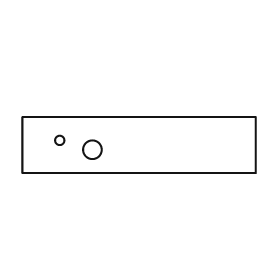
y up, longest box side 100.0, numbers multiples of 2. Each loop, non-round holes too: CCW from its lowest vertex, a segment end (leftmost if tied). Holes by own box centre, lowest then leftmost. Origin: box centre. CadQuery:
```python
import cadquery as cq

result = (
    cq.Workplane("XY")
    .moveTo(-50.0, -12.0)
    .lineTo(50.0, -12.0)
    .lineTo(50.0, 12.0)
    .lineTo(-50.0, 12.0)
    .close()
    .moveTo(-20.0, -2.0)
    .circle(4.0)
    .moveTo(-34.0, 2.0)
    .circle(2.0)
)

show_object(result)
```